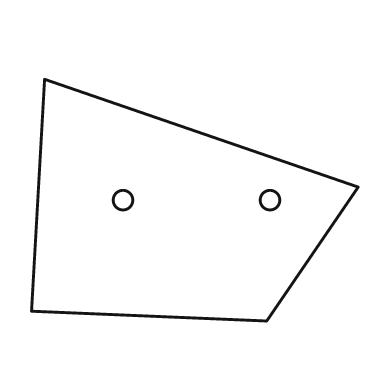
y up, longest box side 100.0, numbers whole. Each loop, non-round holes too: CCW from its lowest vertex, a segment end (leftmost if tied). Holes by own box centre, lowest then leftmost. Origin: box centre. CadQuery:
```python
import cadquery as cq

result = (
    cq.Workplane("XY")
    .moveTo(22.0, -37.0)
    .lineTo(50.0, 4.0)
    .lineTo(-46.0, 37.0)
    .lineTo(-50.0, -34.0)
    .close()
    .moveTo(-22.0, 0.0)
    .circle(3.0)
    .moveTo(23.0, 0.0)
    .circle(3.0)
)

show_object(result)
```